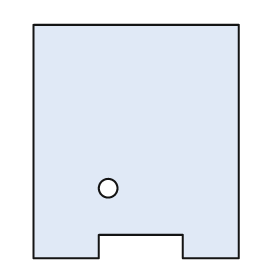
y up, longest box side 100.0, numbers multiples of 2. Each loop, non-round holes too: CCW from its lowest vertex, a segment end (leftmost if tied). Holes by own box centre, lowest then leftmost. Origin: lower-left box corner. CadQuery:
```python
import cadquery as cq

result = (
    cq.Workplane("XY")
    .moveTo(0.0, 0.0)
    .lineTo(28.0, 0.0)
    .lineTo(28.0, 10.0)
    .lineTo(64.0, 10.0)
    .lineTo(64.0, 0.0)
    .lineTo(88.0, 0.0)
    .lineTo(88.0, 100.0)
    .lineTo(0.0, 100.0)
    .close()
    .moveTo(32.0, 30.0)
    .circle(4.0)
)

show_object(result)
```